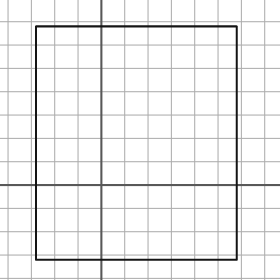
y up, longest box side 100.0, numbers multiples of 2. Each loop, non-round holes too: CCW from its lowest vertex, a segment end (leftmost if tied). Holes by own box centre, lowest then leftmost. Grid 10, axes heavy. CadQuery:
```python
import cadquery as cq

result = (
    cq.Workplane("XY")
    .moveTo(-28.0, -32.0)
    .lineTo(58.0, -32.0)
    .lineTo(58.0, 68.0)
    .lineTo(-28.0, 68.0)
    .close()
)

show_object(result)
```